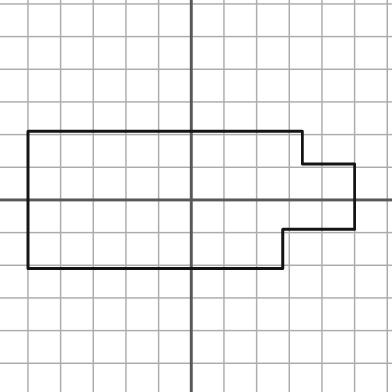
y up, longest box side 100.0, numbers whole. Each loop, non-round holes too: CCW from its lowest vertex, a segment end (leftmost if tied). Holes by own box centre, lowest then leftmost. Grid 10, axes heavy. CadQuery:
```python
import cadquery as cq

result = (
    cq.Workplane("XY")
    .moveTo(-50.0, -21.0)
    .lineTo(28.0, -21.0)
    .lineTo(28.0, -9.0)
    .lineTo(50.0, -9.0)
    .lineTo(50.0, 11.0)
    .lineTo(34.0, 11.0)
    .lineTo(34.0, 21.0)
    .lineTo(-50.0, 21.0)
    .close()
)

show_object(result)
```